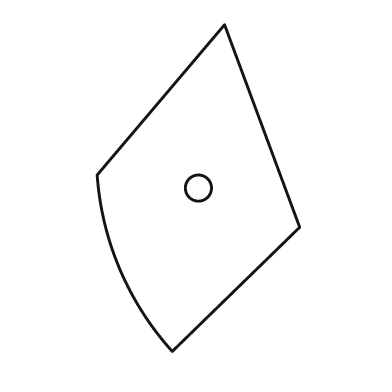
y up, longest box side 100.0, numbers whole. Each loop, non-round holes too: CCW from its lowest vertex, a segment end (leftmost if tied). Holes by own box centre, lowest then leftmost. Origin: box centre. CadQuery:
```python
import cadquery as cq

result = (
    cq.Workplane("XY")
    .moveTo(-8.0, -50.0)
    .lineTo(31.0, -12.0)
    .lineTo(8.0, 50.0)
    .lineTo(-31.0, 4.0)
    .threePointArc((-24.0, -25.0), (-8.0, -50.0))
    .close()
    .moveTo(0.0, 0.0)
    .circle(4.0)
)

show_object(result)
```